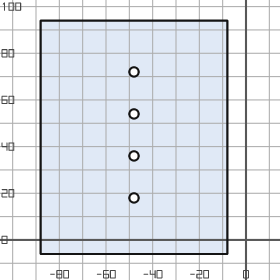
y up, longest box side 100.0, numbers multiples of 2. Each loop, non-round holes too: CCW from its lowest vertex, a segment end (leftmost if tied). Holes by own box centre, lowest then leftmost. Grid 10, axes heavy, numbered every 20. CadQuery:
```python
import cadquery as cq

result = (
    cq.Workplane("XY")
    .moveTo(-88.0, -6.0)
    .lineTo(-8.0, -6.0)
    .lineTo(-8.0, 94.0)
    .lineTo(-88.0, 94.0)
    .close()
    .moveTo(-48.0, 18.0)
    .circle(2.0)
    .moveTo(-48.0, 36.0)
    .circle(2.0)
    .moveTo(-48.0, 54.0)
    .circle(2.0)
    .moveTo(-48.0, 72.0)
    .circle(2.0)
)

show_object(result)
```